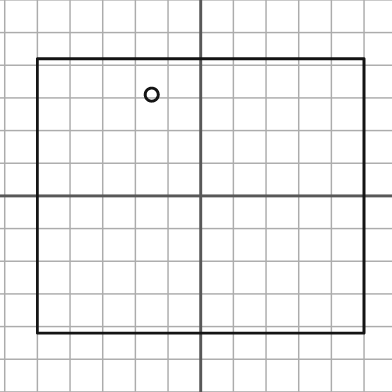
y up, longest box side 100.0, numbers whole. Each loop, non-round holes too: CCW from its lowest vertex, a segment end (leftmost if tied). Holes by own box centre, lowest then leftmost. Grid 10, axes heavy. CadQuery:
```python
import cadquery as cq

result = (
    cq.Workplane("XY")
    .moveTo(-50.0, -42.0)
    .lineTo(50.0, -42.0)
    .lineTo(50.0, 42.0)
    .lineTo(-50.0, 42.0)
    .close()
    .moveTo(-15.0, 31.0)
    .circle(2.0)
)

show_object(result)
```